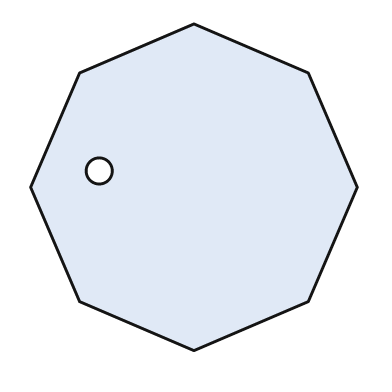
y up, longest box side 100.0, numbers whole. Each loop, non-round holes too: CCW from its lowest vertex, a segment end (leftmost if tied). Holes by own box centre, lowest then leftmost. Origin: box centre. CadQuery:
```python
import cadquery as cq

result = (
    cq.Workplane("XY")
    .moveTo(0.0, -50.0)
    .lineTo(35.0, -35.0)
    .lineTo(50.0, 0.0)
    .lineTo(35.0, 35.0)
    .lineTo(0.0, 50.0)
    .lineTo(-35.0, 35.0)
    .lineTo(-50.0, 0.0)
    .lineTo(-35.0, -35.0)
    .close()
    .moveTo(-29.0, 5.0)
    .circle(4.0)
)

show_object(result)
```